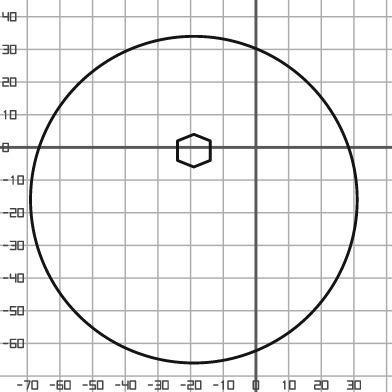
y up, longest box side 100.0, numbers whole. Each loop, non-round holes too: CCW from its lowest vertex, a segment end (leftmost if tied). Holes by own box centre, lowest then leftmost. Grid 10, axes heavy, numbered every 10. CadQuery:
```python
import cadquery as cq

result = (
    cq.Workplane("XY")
    .moveTo(-19.0, -16.0)
    .circle(50.0)
    .moveTo(-19.0, -6.0)
    .lineTo(-14.0, -4.0)
    .lineTo(-14.0, 2.0)
    .lineTo(-19.0, 4.0)
    .lineTo(-24.0, 2.0)
    .lineTo(-24.0, -4.0)
    .close()
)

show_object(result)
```